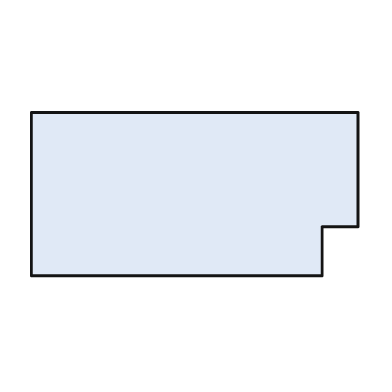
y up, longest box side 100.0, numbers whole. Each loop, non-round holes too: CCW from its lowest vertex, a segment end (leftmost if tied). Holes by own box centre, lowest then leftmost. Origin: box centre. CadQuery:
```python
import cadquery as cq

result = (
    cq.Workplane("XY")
    .moveTo(-50.0, -25.0)
    .lineTo(39.0, -25.0)
    .lineTo(39.0, -10.0)
    .lineTo(50.0, -10.0)
    .lineTo(50.0, 25.0)
    .lineTo(-50.0, 25.0)
    .close()
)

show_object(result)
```